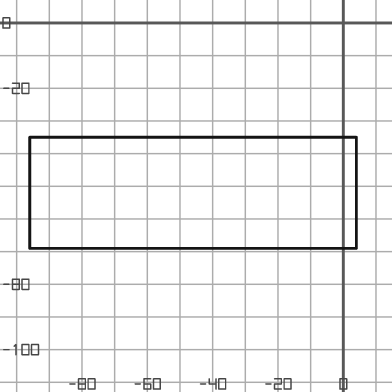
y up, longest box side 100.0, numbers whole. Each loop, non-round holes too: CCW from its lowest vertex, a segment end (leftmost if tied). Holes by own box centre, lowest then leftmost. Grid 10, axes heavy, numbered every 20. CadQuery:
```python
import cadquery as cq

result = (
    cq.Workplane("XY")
    .moveTo(-96.0, -69.0)
    .lineTo(4.0, -69.0)
    .lineTo(4.0, -35.0)
    .lineTo(-96.0, -35.0)
    .close()
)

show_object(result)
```